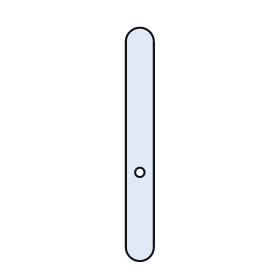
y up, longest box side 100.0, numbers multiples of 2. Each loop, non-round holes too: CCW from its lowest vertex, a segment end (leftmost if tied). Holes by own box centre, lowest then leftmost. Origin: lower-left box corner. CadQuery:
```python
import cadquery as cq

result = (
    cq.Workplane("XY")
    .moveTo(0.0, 6.0)
    .threePointArc((6.0, 0.0), (12.0, 6.0))
    .lineTo(12.0, 94.0)
    .threePointArc((6.0, 100.0), (0.0, 94.0))
    .close()
    .moveTo(6.0, 38.0)
    .circle(2.0)
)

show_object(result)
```